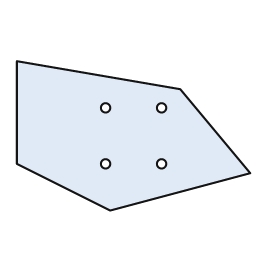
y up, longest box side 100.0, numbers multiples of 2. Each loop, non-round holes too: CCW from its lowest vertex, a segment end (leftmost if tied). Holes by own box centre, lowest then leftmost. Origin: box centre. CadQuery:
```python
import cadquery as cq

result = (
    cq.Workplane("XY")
    .moveTo(-10.0, -32.0)
    .lineTo(50.0, -16.0)
    .lineTo(20.0, 20.0)
    .lineTo(-50.0, 32.0)
    .lineTo(-50.0, -12.0)
    .close()
    .moveTo(-12.0, -12.0)
    .circle(2.0)
    .moveTo(12.0, -12.0)
    .circle(2.0)
    .moveTo(-12.0, 12.0)
    .circle(2.0)
    .moveTo(12.0, 12.0)
    .circle(2.0)
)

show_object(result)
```